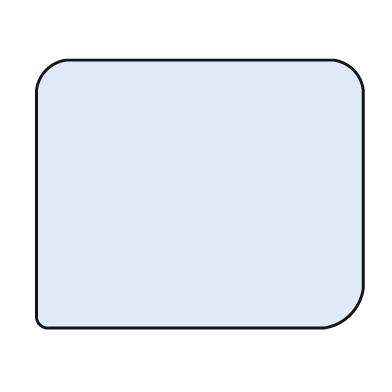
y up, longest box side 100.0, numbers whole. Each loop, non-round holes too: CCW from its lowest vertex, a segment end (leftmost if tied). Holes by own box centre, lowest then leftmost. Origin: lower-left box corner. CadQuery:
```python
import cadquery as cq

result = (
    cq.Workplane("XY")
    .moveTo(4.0, 0.0)
    .lineTo(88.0, 0.0)
    .threePointArc((96.0, 4.0), (100.0, 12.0))
    .lineTo(100.0, 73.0)
    .threePointArc((97.0, 79.0), (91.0, 82.0))
    .lineTo(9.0, 82.0)
    .threePointArc((3.0, 79.0), (0.0, 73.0))
    .lineTo(0.0, 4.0)
    .threePointArc((1.0, 1.0), (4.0, 0.0))
    .close()
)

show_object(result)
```